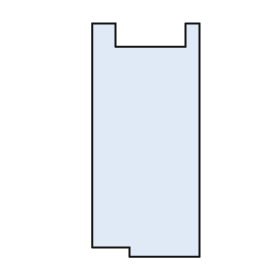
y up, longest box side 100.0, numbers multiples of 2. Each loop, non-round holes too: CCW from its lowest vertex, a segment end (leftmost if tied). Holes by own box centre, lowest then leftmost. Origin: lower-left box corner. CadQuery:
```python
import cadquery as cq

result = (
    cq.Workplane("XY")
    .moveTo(16.0, 0.0)
    .lineTo(46.0, 0.0)
    .lineTo(46.0, 100.0)
    .lineTo(40.0, 100.0)
    .lineTo(40.0, 90.0)
    .lineTo(10.0, 90.0)
    .lineTo(10.0, 100.0)
    .lineTo(0.0, 100.0)
    .lineTo(0.0, 4.0)
    .lineTo(16.0, 4.0)
    .close()
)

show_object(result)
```